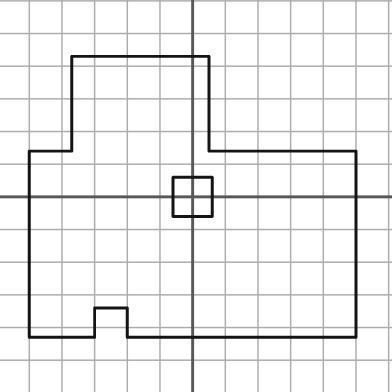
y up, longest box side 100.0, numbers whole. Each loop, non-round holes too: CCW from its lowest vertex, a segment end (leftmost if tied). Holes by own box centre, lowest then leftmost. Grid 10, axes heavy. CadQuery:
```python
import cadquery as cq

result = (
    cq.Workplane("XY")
    .moveTo(-50.0, -43.0)
    .lineTo(-30.0, -43.0)
    .lineTo(-30.0, -34.0)
    .lineTo(-20.0, -34.0)
    .lineTo(-20.0, -43.0)
    .lineTo(50.0, -43.0)
    .lineTo(50.0, 14.0)
    .lineTo(5.0, 14.0)
    .lineTo(5.0, 43.0)
    .lineTo(-37.0, 43.0)
    .lineTo(-37.0, 14.0)
    .lineTo(-50.0, 14.0)
    .close()
    .moveTo(-6.0, -6.0)
    .lineTo(6.0, -6.0)
    .lineTo(6.0, 6.0)
    .lineTo(-6.0, 6.0)
    .close()
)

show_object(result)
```